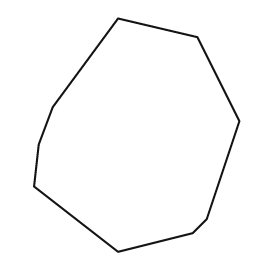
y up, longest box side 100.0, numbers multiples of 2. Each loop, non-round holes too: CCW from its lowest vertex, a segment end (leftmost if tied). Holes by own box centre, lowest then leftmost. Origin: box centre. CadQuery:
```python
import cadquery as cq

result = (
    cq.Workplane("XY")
    .moveTo(-8.0, -50.0)
    .lineTo(24.0, -42.0)
    .lineTo(30.0, -36.0)
    .lineTo(44.0, 6.0)
    .lineTo(26.0, 42.0)
    .lineTo(-8.0, 50.0)
    .lineTo(-36.0, 12.0)
    .lineTo(-42.0, -4.0)
    .lineTo(-44.0, -22.0)
    .close()
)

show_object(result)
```